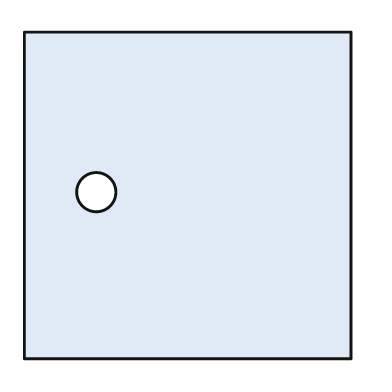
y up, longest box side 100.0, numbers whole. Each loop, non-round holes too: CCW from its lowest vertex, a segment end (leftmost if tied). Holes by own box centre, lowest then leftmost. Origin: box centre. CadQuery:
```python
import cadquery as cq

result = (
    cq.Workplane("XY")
    .moveTo(-50.0, -50.0)
    .lineTo(50.0, -50.0)
    .lineTo(50.0, 50.0)
    .lineTo(-50.0, 50.0)
    .close()
    .moveTo(-28.0, 1.0)
    .circle(6.0)
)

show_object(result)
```